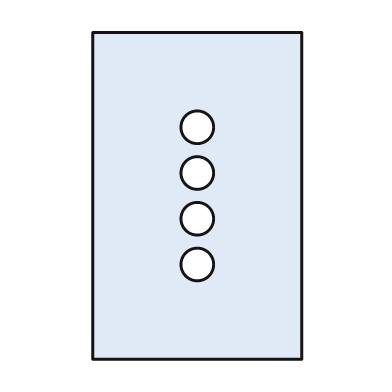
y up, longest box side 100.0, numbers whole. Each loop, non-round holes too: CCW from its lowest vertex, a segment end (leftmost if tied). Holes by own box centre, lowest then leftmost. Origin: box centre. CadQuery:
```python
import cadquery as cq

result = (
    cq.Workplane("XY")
    .moveTo(-32.0, -50.0)
    .lineTo(32.0, -50.0)
    .lineTo(32.0, 50.0)
    .lineTo(-32.0, 50.0)
    .close()
    .moveTo(0.0, -21.0)
    .circle(5.0)
    .moveTo(0.0, -7.0)
    .circle(5.0)
    .moveTo(0.0, 7.0)
    .circle(5.0)
    .moveTo(0.0, 21.0)
    .circle(5.0)
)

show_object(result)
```